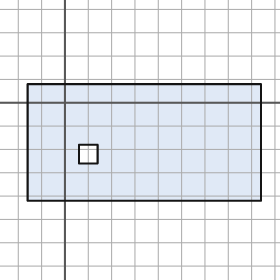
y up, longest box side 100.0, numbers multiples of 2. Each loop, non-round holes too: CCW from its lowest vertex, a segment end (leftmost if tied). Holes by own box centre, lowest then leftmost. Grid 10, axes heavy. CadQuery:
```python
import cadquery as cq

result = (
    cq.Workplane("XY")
    .moveTo(-16.0, -42.0)
    .lineTo(84.0, -42.0)
    .lineTo(84.0, 8.0)
    .lineTo(-16.0, 8.0)
    .close()
    .moveTo(6.0, -26.0)
    .lineTo(14.0, -26.0)
    .lineTo(14.0, -18.0)
    .lineTo(6.0, -18.0)
    .close()
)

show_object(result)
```